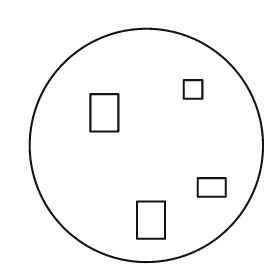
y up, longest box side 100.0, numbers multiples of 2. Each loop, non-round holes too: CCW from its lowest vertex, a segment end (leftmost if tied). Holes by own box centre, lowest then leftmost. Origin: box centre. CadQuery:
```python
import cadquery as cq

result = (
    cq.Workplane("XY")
    .moveTo(0.0, 0.0)
    .circle(50.0)
    .moveTo(-4.0, -40.0)
    .lineTo(8.0, -40.0)
    .lineTo(8.0, -24.0)
    .lineTo(-4.0, -24.0)
    .close()
    .moveTo(22.0, -22.0)
    .lineTo(34.0, -22.0)
    .lineTo(34.0, -14.0)
    .lineTo(22.0, -14.0)
    .close()
    .moveTo(-24.0, 6.0)
    .lineTo(-12.0, 6.0)
    .lineTo(-12.0, 22.0)
    .lineTo(-24.0, 22.0)
    .close()
    .moveTo(16.0, 20.0)
    .lineTo(24.0, 20.0)
    .lineTo(24.0, 28.0)
    .lineTo(16.0, 28.0)
    .close()
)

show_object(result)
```